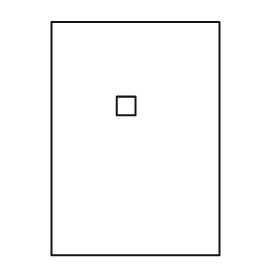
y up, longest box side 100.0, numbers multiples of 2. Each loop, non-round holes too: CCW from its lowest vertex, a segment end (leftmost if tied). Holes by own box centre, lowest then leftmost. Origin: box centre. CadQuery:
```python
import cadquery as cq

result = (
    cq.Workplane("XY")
    .moveTo(-36.0, -50.0)
    .lineTo(36.0, -50.0)
    .lineTo(36.0, 50.0)
    .lineTo(-36.0, 50.0)
    .close()
    .moveTo(-8.0, 10.0)
    .lineTo(0.0, 10.0)
    .lineTo(0.0, 18.0)
    .lineTo(-8.0, 18.0)
    .close()
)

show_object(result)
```